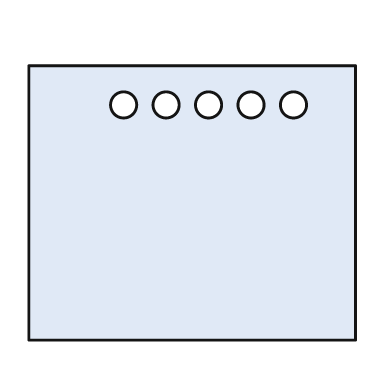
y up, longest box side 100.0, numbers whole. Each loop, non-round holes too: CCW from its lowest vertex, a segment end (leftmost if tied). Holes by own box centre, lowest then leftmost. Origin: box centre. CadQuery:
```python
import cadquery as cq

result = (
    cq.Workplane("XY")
    .moveTo(-50.0, -42.0)
    .lineTo(50.0, -42.0)
    .lineTo(50.0, 42.0)
    .lineTo(-50.0, 42.0)
    .close()
    .moveTo(-21.0, 30.0)
    .circle(4.0)
    .moveTo(-8.0, 30.0)
    .circle(4.0)
    .moveTo(5.0, 30.0)
    .circle(4.0)
    .moveTo(18.0, 30.0)
    .circle(4.0)
    .moveTo(31.0, 30.0)
    .circle(4.0)
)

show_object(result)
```